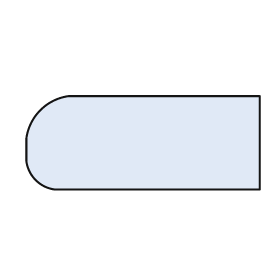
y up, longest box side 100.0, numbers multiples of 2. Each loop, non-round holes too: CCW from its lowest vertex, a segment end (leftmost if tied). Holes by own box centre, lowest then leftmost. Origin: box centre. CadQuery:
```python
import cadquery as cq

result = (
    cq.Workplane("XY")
    .moveTo(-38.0, -20.0)
    .lineTo(50.0, -20.0)
    .lineTo(50.0, 20.0)
    .lineTo(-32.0, 20.0)
    .threePointArc((-44.0, 14.0), (-50.0, 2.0))
    .lineTo(-50.0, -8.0)
    .threePointArc((-46.0, -16.0), (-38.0, -20.0))
    .close()
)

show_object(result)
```